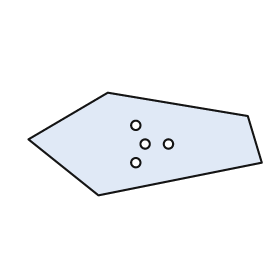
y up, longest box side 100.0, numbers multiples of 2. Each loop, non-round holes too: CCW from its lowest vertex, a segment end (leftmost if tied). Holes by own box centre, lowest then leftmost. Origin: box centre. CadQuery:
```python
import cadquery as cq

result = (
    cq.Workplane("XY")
    .moveTo(-20.0, -22.0)
    .lineTo(50.0, -8.0)
    .lineTo(44.0, 12.0)
    .lineTo(-16.0, 22.0)
    .lineTo(-50.0, 2.0)
    .close()
    .moveTo(-4.0, -8.0)
    .circle(2.0)
    .moveTo(0.0, 0.0)
    .circle(2.0)
    .moveTo(10.0, 0.0)
    .circle(2.0)
    .moveTo(-4.0, 8.0)
    .circle(2.0)
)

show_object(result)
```